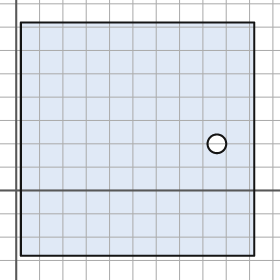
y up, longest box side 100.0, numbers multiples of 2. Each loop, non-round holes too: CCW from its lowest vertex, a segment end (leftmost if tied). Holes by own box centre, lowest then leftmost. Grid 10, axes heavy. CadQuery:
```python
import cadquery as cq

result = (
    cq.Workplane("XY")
    .moveTo(2.0, -28.0)
    .lineTo(102.0, -28.0)
    .lineTo(102.0, 72.0)
    .lineTo(2.0, 72.0)
    .close()
    .moveTo(86.0, 20.0)
    .circle(4.0)
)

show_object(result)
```